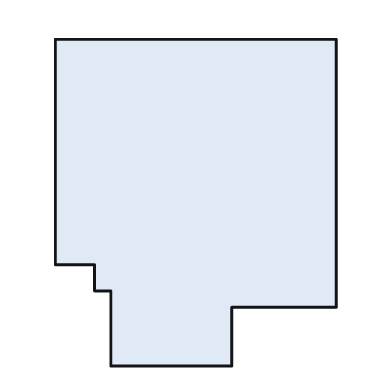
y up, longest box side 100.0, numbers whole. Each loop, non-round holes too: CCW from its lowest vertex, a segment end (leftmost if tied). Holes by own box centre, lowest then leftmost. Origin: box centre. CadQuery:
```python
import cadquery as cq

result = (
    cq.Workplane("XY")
    .moveTo(-26.0, -50.0)
    .lineTo(11.0, -50.0)
    .lineTo(11.0, -32.0)
    .lineTo(43.0, -32.0)
    .lineTo(43.0, 50.0)
    .lineTo(-43.0, 50.0)
    .lineTo(-43.0, -19.0)
    .lineTo(-31.0, -19.0)
    .lineTo(-31.0, -27.0)
    .lineTo(-26.0, -27.0)
    .close()
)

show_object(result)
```